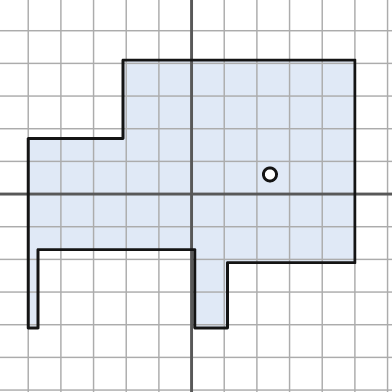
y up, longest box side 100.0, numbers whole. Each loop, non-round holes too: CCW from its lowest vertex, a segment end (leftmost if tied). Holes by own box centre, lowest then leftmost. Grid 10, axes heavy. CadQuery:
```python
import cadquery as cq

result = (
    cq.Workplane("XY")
    .moveTo(-50.0, -41.0)
    .lineTo(-47.0, -41.0)
    .lineTo(-47.0, -17.0)
    .lineTo(1.0, -17.0)
    .lineTo(1.0, -41.0)
    .lineTo(11.0, -41.0)
    .lineTo(11.0, -21.0)
    .lineTo(50.0, -21.0)
    .lineTo(50.0, 41.0)
    .lineTo(-21.0, 41.0)
    .lineTo(-21.0, 17.0)
    .lineTo(-50.0, 17.0)
    .close()
    .moveTo(24.0, 6.0)
    .circle(2.0)
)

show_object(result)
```